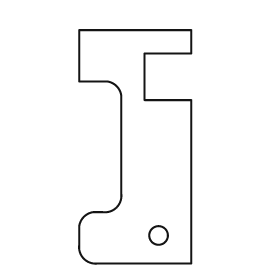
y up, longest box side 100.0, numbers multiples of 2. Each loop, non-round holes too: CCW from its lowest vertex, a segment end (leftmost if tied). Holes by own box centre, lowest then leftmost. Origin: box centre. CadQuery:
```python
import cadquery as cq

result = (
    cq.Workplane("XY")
    .moveTo(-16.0, -50.0)
    .lineTo(24.0, -50.0)
    .lineTo(24.0, 20.0)
    .lineTo(4.0, 20.0)
    .lineTo(4.0, 40.0)
    .lineTo(24.0, 40.0)
    .lineTo(24.0, 50.0)
    .lineTo(-24.0, 50.0)
    .lineTo(-24.0, 28.0)
    .lineTo(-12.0, 28.0)
    .threePointArc((-8.0, 26.0), (-6.0, 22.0))
    .lineTo(-6.0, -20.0)
    .threePointArc((-8.0, -26.0), (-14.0, -28.0))
    .lineTo(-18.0, -28.0)
    .threePointArc((-22.0, -30.0), (-24.0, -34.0))
    .lineTo(-24.0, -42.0)
    .threePointArc((-22.0, -48.0), (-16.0, -50.0))
    .close()
    .moveTo(10.0, -38.0)
    .circle(4.0)
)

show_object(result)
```